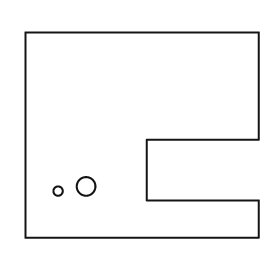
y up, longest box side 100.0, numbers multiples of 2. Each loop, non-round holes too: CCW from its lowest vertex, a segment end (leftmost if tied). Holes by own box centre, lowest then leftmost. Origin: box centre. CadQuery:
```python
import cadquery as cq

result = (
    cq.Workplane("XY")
    .moveTo(-50.0, -44.0)
    .lineTo(50.0, -44.0)
    .lineTo(50.0, -28.0)
    .lineTo(2.0, -28.0)
    .lineTo(2.0, -2.0)
    .lineTo(50.0, -2.0)
    .lineTo(50.0, 44.0)
    .lineTo(-50.0, 44.0)
    .close()
    .moveTo(-36.0, -24.0)
    .circle(2.0)
    .moveTo(-24.0, -22.0)
    .circle(4.0)
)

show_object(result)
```